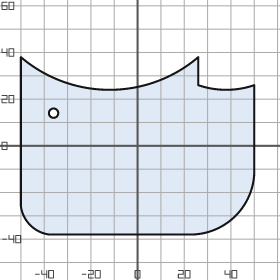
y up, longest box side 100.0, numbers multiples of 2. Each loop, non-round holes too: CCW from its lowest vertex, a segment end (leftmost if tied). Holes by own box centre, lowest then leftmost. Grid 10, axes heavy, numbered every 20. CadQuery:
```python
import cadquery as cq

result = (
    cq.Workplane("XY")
    .moveTo(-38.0, -38.0)
    .lineTo(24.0, -38.0)
    .threePointArc((42.0, -30.0), (50.0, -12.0))
    .lineTo(50.0, 26.0)
    .threePointArc((38.0, 24.0), (26.0, 26.0))
    .lineTo(26.0, 38.0)
    .threePointArc((-12.0, 24.0), (-50.0, 38.0))
    .lineTo(-50.0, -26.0)
    .threePointArc((-46.0, -34.0), (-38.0, -38.0))
    .close()
    .moveTo(-36.0, 14.0)
    .circle(2.0)
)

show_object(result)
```